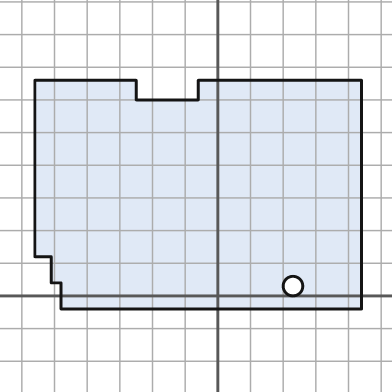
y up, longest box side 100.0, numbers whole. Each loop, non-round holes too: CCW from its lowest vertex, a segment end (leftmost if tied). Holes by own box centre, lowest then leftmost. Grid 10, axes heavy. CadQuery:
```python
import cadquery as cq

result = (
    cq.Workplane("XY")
    .moveTo(-48.0, -4.0)
    .lineTo(44.0, -4.0)
    .lineTo(44.0, 66.0)
    .lineTo(-6.0, 66.0)
    .lineTo(-6.0, 60.0)
    .lineTo(-25.0, 60.0)
    .lineTo(-25.0, 66.0)
    .lineTo(-56.0, 66.0)
    .lineTo(-56.0, 12.0)
    .lineTo(-51.0, 12.0)
    .lineTo(-51.0, 4.0)
    .lineTo(-48.0, 4.0)
    .close()
    .moveTo(23.0, 3.0)
    .circle(3.0)
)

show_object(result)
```